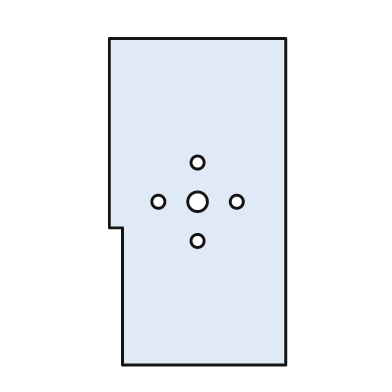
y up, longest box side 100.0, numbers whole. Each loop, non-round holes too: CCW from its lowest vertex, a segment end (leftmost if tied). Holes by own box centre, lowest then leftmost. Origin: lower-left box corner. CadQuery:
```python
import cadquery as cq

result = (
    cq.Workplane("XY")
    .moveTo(4.0, 0.0)
    .lineTo(54.0, 0.0)
    .lineTo(54.0, 100.0)
    .lineTo(0.0, 100.0)
    .lineTo(0.0, 42.0)
    .lineTo(4.0, 42.0)
    .close()
    .moveTo(27.0, 38.0)
    .circle(2.0)
    .moveTo(15.0, 50.0)
    .circle(2.0)
    .moveTo(27.0, 50.0)
    .circle(3.0)
    .moveTo(39.0, 50.0)
    .circle(2.0)
    .moveTo(27.0, 62.0)
    .circle(2.0)
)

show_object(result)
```